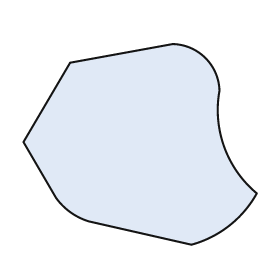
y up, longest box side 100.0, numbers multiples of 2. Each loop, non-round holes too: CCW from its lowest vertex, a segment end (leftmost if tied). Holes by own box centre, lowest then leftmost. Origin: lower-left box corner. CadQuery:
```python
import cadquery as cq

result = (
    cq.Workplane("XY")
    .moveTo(72.0, 0.0)
    .threePointArc((88.0, 8.0), (100.0, 22.0))
    .threePointArc((86.0, 42.0), (84.0, 66.0))
    .threePointArc((78.0, 80.0), (64.0, 86.0))
    .lineTo(20.0, 78.0)
    .lineTo(0.0, 44.0)
    .lineTo(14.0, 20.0)
    .threePointArc((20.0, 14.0), (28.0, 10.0))
    .close()
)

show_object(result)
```